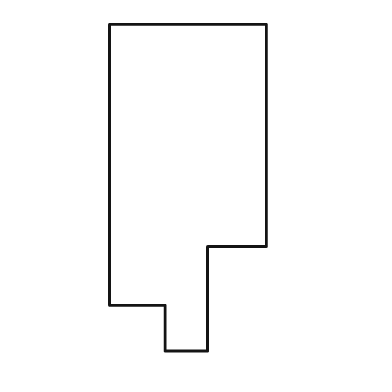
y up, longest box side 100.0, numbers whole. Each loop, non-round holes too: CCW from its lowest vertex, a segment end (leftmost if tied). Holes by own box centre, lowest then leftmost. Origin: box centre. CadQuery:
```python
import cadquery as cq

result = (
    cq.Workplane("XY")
    .moveTo(-7.0, -50.0)
    .lineTo(6.0, -50.0)
    .lineTo(6.0, -18.0)
    .lineTo(24.0, -18.0)
    .lineTo(24.0, 50.0)
    .lineTo(-24.0, 50.0)
    .lineTo(-24.0, -36.0)
    .lineTo(-7.0, -36.0)
    .close()
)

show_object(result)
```